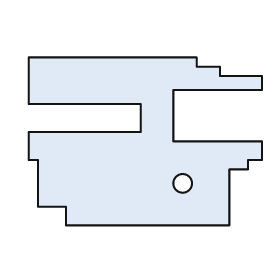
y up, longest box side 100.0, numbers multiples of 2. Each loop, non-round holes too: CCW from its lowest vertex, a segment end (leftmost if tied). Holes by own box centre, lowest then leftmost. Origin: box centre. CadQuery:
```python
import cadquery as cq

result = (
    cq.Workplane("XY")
    .moveTo(-34.0, -36.0)
    .lineTo(36.0, -36.0)
    .lineTo(36.0, -12.0)
    .lineTo(44.0, -12.0)
    .lineTo(44.0, -8.0)
    .lineTo(50.0, -8.0)
    .lineTo(50.0, 0.0)
    .lineTo(12.0, 0.0)
    .lineTo(12.0, 22.0)
    .lineTo(50.0, 22.0)
    .lineTo(50.0, 28.0)
    .lineTo(32.0, 28.0)
    .lineTo(32.0, 32.0)
    .lineTo(22.0, 32.0)
    .lineTo(22.0, 36.0)
    .lineTo(-50.0, 36.0)
    .lineTo(-50.0, 16.0)
    .lineTo(-2.0, 16.0)
    .lineTo(-2.0, 4.0)
    .lineTo(-50.0, 4.0)
    .lineTo(-50.0, -8.0)
    .lineTo(-46.0, -8.0)
    .lineTo(-46.0, -28.0)
    .lineTo(-34.0, -28.0)
    .close()
    .moveTo(16.0, -18.0)
    .circle(4.0)
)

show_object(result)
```